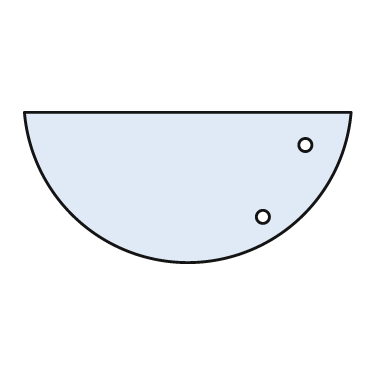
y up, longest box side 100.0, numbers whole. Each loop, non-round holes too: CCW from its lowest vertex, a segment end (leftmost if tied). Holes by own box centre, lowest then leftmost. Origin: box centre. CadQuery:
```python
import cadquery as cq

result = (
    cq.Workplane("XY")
    .moveTo(-50.0, 23.0)
    .threePointArc((0.0, -23.0), (50.0, 23.0))
    .close()
    .moveTo(23.0, -9.0)
    .circle(2.0)
    .moveTo(36.0, 13.0)
    .circle(2.0)
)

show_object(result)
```